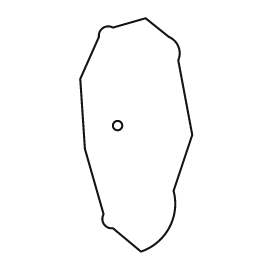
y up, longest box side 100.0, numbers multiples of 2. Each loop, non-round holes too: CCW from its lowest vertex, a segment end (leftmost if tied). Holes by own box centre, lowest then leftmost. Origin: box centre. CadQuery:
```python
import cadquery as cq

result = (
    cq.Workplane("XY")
    .moveTo(2.0, -50.0)
    .threePointArc((14.0, -40.0), (16.0, -24.0))
    .lineTo(24.0, 0.0)
    .lineTo(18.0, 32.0)
    .threePointArc((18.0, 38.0), (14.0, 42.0))
    .lineTo(4.0, 50.0)
    .lineTo(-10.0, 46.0)
    .threePointArc((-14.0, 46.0), (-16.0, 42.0))
    .lineTo(-24.0, 24.0)
    .lineTo(-22.0, -6.0)
    .lineTo(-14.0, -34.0)
    .threePointArc((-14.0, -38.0), (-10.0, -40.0))
    .close()
    .moveTo(-8.0, 4.0)
    .circle(2.0)
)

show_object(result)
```